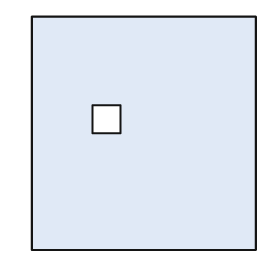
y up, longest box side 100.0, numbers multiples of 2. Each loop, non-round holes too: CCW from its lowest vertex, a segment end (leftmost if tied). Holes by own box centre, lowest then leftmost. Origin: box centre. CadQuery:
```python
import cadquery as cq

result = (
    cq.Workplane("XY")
    .moveTo(-48.0, -50.0)
    .lineTo(48.0, -50.0)
    .lineTo(48.0, 50.0)
    .lineTo(-48.0, 50.0)
    .close()
    .moveTo(-22.0, 0.0)
    .lineTo(-10.0, 0.0)
    .lineTo(-10.0, 12.0)
    .lineTo(-22.0, 12.0)
    .close()
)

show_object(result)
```